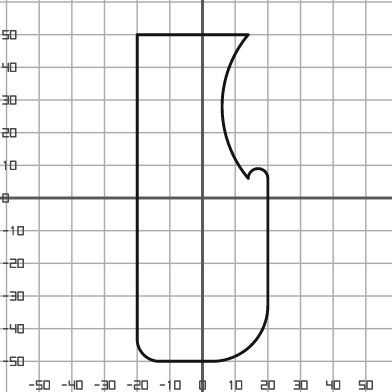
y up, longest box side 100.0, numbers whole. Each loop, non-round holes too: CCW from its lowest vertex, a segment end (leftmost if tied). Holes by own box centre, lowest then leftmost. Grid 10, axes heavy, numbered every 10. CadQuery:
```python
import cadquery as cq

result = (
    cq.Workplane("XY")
    .moveTo(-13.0, -50.0)
    .lineTo(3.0, -50.0)
    .threePointArc((15.0, -45.0), (20.0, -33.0))
    .lineTo(20.0, 6.0)
    .threePointArc((17.0, 9.0), (14.0, 6.0))
    .threePointArc((6.0, 28.0), (14.0, 50.0))
    .lineTo(-20.0, 50.0)
    .lineTo(-20.0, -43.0)
    .threePointArc((-18.0, -48.0), (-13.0, -50.0))
    .close()
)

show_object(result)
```